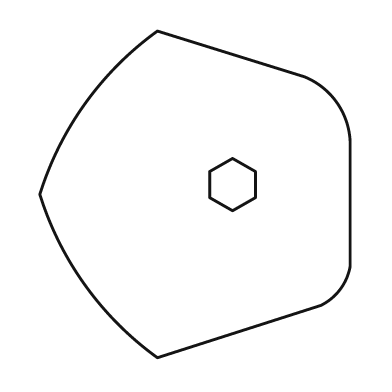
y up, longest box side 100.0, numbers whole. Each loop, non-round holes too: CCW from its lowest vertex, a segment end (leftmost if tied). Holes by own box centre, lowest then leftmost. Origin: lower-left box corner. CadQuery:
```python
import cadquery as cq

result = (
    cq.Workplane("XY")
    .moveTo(36.0, 0.0)
    .lineTo(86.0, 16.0)
    .threePointArc((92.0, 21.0), (95.0, 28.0))
    .lineTo(95.0, 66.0)
    .threePointArc((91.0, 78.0), (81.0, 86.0))
    .lineTo(36.0, 100.0)
    .threePointArc((14.0, 78.0), (0.0, 50.0))
    .threePointArc((14.0, 22.0), (36.0, 0.0))
    .close()
    .moveTo(59.0, 45.0)
    .lineTo(66.0, 49.0)
    .lineTo(66.0, 57.0)
    .lineTo(59.0, 61.0)
    .lineTo(52.0, 57.0)
    .lineTo(52.0, 49.0)
    .close()
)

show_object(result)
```